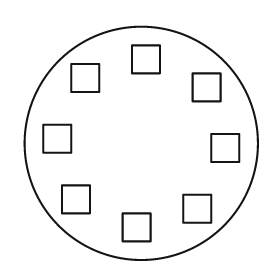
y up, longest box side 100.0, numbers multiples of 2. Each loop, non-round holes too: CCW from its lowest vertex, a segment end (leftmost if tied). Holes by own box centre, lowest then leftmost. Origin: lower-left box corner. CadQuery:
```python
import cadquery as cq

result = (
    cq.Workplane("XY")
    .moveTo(50.0, 50.0)
    .circle(50.0)
    .moveTo(42.0, 8.0)
    .lineTo(54.0, 8.0)
    .lineTo(54.0, 20.0)
    .lineTo(42.0, 20.0)
    .close()
    .moveTo(68.0, 16.0)
    .lineTo(80.0, 16.0)
    .lineTo(80.0, 28.0)
    .lineTo(68.0, 28.0)
    .close()
    .moveTo(16.0, 20.0)
    .lineTo(28.0, 20.0)
    .lineTo(28.0, 32.0)
    .lineTo(16.0, 32.0)
    .close()
    .moveTo(80.0, 42.0)
    .lineTo(92.0, 42.0)
    .lineTo(92.0, 54.0)
    .lineTo(80.0, 54.0)
    .close()
    .moveTo(8.0, 46.0)
    .lineTo(20.0, 46.0)
    .lineTo(20.0, 58.0)
    .lineTo(8.0, 58.0)
    .close()
    .moveTo(72.0, 68.0)
    .lineTo(84.0, 68.0)
    .lineTo(84.0, 80.0)
    .lineTo(72.0, 80.0)
    .close()
    .moveTo(20.0, 72.0)
    .lineTo(32.0, 72.0)
    .lineTo(32.0, 84.0)
    .lineTo(20.0, 84.0)
    .close()
    .moveTo(46.0, 80.0)
    .lineTo(58.0, 80.0)
    .lineTo(58.0, 92.0)
    .lineTo(46.0, 92.0)
    .close()
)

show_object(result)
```